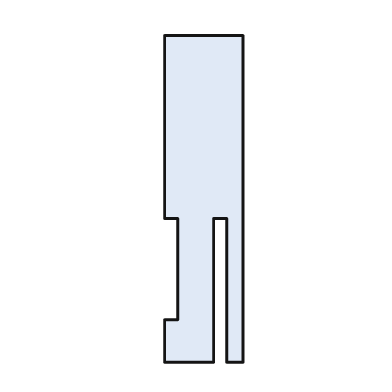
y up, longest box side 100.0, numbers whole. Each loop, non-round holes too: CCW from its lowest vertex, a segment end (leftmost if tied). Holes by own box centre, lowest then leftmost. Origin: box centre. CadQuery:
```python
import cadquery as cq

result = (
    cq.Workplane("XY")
    .moveTo(-12.0, -50.0)
    .lineTo(3.0, -50.0)
    .lineTo(3.0, -6.0)
    .lineTo(7.0, -6.0)
    .lineTo(7.0, -50.0)
    .lineTo(12.0, -50.0)
    .lineTo(12.0, 50.0)
    .lineTo(-12.0, 50.0)
    .lineTo(-12.0, -6.0)
    .lineTo(-8.0, -6.0)
    .lineTo(-8.0, -37.0)
    .lineTo(-12.0, -37.0)
    .close()
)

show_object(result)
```